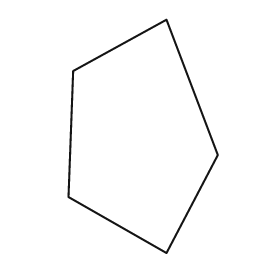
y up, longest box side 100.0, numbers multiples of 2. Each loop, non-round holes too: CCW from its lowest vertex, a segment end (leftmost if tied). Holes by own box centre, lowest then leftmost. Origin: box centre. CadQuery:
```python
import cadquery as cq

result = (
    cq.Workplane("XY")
    .moveTo(10.0, -50.0)
    .lineTo(32.0, -8.0)
    .lineTo(10.0, 50.0)
    .lineTo(-30.0, 28.0)
    .lineTo(-32.0, -26.0)
    .close()
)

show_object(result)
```